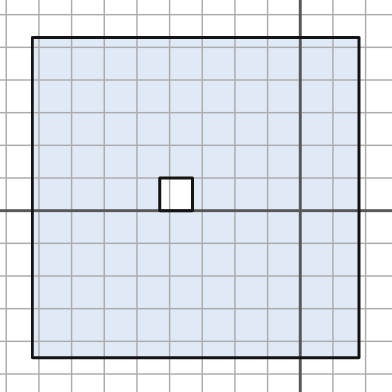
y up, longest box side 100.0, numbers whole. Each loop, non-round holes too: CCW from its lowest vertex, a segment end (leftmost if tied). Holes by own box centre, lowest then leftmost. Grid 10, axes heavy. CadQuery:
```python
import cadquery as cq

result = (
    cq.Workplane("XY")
    .moveTo(-82.0, -45.0)
    .lineTo(18.0, -45.0)
    .lineTo(18.0, 53.0)
    .lineTo(-82.0, 53.0)
    .close()
    .moveTo(-43.0, 0.0)
    .lineTo(-33.0, 0.0)
    .lineTo(-33.0, 10.0)
    .lineTo(-43.0, 10.0)
    .close()
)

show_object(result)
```